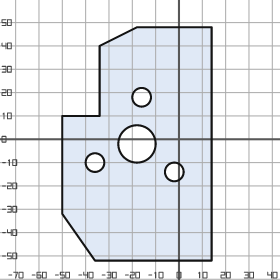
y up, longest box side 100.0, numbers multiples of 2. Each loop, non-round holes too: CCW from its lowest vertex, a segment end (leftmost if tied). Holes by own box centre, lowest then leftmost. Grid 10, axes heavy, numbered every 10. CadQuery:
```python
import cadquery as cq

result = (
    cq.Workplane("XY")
    .moveTo(-36.0, -52.0)
    .lineTo(14.0, -52.0)
    .lineTo(14.0, 48.0)
    .lineTo(-18.0, 48.0)
    .lineTo(-34.0, 40.0)
    .lineTo(-34.0, 10.0)
    .lineTo(-50.0, 10.0)
    .lineTo(-50.0, -32.0)
    .close()
    .moveTo(-2.0, -14.0)
    .circle(4.0)
    .moveTo(-36.0, -10.0)
    .circle(4.0)
    .moveTo(-18.0, -2.0)
    .circle(8.0)
    .moveTo(-16.0, 18.0)
    .circle(4.0)
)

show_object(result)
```